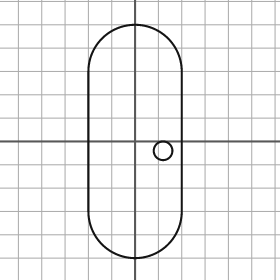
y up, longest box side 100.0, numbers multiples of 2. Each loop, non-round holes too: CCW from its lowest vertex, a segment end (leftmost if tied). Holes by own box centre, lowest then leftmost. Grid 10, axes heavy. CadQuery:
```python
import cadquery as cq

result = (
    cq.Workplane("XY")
    .moveTo(-20.0, -30.0)
    .threePointArc((0.0, -50.0), (20.0, -30.0))
    .lineTo(20.0, 30.0)
    .threePointArc((0.0, 50.0), (-20.0, 30.0))
    .close()
    .moveTo(12.0, -4.0)
    .circle(4.0)
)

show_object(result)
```